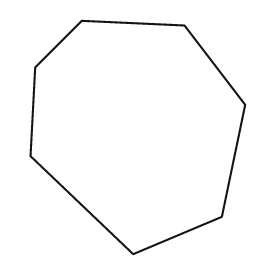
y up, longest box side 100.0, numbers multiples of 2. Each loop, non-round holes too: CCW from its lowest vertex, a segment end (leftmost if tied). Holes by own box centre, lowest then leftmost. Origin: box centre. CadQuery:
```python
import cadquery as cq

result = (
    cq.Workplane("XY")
    .moveTo(-2.0, -50.0)
    .lineTo(36.0, -34.0)
    .lineTo(46.0, 14.0)
    .lineTo(20.0, 48.0)
    .lineTo(-24.0, 50.0)
    .lineTo(-44.0, 30.0)
    .lineTo(-46.0, -8.0)
    .close()
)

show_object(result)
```